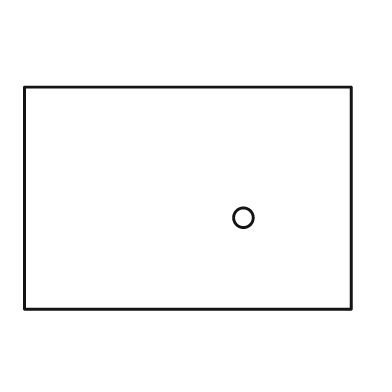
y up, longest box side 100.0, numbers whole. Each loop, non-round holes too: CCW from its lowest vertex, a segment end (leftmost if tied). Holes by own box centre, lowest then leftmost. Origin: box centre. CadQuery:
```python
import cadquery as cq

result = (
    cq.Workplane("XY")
    .moveTo(-50.0, -34.0)
    .lineTo(50.0, -34.0)
    .lineTo(50.0, 34.0)
    .lineTo(-50.0, 34.0)
    .close()
    .moveTo(17.0, -6.0)
    .circle(3.0)
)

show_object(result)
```